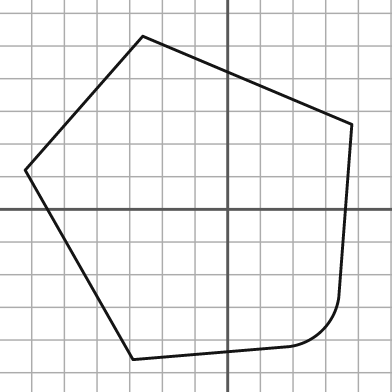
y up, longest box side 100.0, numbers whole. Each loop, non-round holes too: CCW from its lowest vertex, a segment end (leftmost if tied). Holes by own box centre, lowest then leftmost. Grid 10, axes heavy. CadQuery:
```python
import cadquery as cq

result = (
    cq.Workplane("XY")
    .moveTo(-29.0, -46.0)
    .lineTo(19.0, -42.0)
    .threePointArc((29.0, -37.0), (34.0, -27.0))
    .lineTo(38.0, 26.0)
    .lineTo(-26.0, 53.0)
    .lineTo(-62.0, 12.0)
    .close()
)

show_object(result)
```